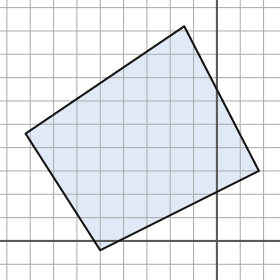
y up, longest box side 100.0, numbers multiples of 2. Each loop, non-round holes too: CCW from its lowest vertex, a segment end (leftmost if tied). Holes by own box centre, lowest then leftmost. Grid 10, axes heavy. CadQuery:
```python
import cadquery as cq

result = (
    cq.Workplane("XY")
    .moveTo(-50.0, -4.0)
    .lineTo(18.0, 30.0)
    .lineTo(-14.0, 92.0)
    .lineTo(-82.0, 46.0)
    .close()
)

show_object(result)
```